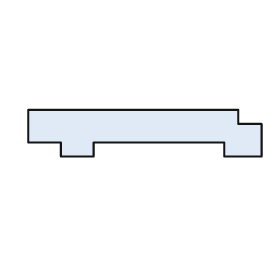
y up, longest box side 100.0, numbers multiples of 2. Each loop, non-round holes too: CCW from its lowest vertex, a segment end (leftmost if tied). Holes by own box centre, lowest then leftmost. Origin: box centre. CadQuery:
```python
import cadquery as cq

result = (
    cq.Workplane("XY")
    .moveTo(-36.0, -10.0)
    .lineTo(-22.0, -10.0)
    .lineTo(-22.0, -4.0)
    .lineTo(34.0, -4.0)
    .lineTo(34.0, -10.0)
    .lineTo(50.0, -10.0)
    .lineTo(50.0, 4.0)
    .lineTo(40.0, 4.0)
    .lineTo(40.0, 10.0)
    .lineTo(-50.0, 10.0)
    .lineTo(-50.0, -4.0)
    .lineTo(-36.0, -4.0)
    .close()
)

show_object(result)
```